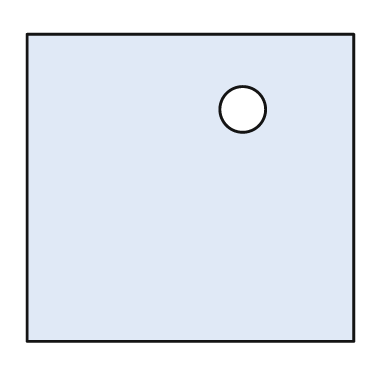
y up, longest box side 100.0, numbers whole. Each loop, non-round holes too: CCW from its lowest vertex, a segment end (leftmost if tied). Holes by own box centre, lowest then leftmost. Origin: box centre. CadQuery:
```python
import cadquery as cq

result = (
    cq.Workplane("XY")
    .moveTo(-50.0, -47.0)
    .lineTo(50.0, -47.0)
    .lineTo(50.0, 47.0)
    .lineTo(-50.0, 47.0)
    .close()
    .moveTo(16.0, 24.0)
    .circle(7.0)
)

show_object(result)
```